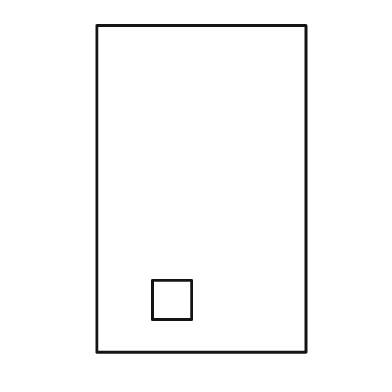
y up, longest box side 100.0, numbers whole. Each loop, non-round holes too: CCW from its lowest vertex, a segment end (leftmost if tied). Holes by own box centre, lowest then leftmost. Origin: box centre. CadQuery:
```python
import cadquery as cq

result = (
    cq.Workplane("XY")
    .moveTo(-32.0, -50.0)
    .lineTo(32.0, -50.0)
    .lineTo(32.0, 50.0)
    .lineTo(-32.0, 50.0)
    .close()
    .moveTo(-15.0, -40.0)
    .lineTo(-3.0, -40.0)
    .lineTo(-3.0, -28.0)
    .lineTo(-15.0, -28.0)
    .close()
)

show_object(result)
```